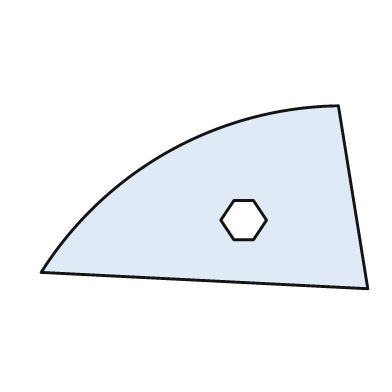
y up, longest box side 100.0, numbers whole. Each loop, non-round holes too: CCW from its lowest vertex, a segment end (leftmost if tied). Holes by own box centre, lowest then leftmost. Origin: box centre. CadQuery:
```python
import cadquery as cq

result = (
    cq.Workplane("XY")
    .moveTo(50.0, -28.0)
    .lineTo(41.0, 28.0)
    .threePointArc((-11.0, 14.0), (-50.0, -23.0))
    .close()
    .moveTo(9.0, -13.0)
    .lineTo(15.0, -13.0)
    .lineTo(19.0, -7.0)
    .lineTo(15.0, -1.0)
    .lineTo(9.0, -1.0)
    .lineTo(5.0, -7.0)
    .close()
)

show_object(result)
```